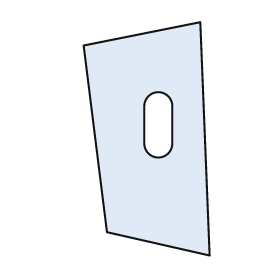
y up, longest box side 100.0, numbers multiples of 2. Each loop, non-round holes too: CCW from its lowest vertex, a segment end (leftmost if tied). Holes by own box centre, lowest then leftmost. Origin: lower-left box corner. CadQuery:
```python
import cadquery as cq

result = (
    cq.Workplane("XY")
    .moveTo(54.0, 0.0)
    .lineTo(50.0, 100.0)
    .lineTo(0.0, 90.0)
    .lineTo(10.0, 10.0)
    .close()
    .moveTo(26.0, 48.0)
    .threePointArc((32.0, 42.0), (38.0, 48.0))
    .lineTo(38.0, 64.0)
    .threePointArc((32.0, 70.0), (26.0, 64.0))
    .close()
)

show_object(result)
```